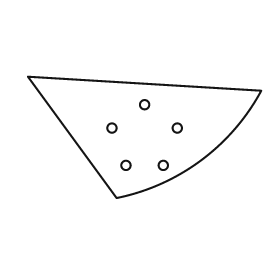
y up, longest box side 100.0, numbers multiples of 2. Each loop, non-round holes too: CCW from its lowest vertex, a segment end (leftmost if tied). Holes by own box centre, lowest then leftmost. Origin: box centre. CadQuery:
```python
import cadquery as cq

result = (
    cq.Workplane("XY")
    .moveTo(-12.0, -26.0)
    .threePointArc((24.0, -10.0), (50.0, 20.0))
    .lineTo(-50.0, 26.0)
    .close()
    .moveTo(-8.0, -12.0)
    .circle(2.0)
    .moveTo(8.0, -12.0)
    .circle(2.0)
    .moveTo(-14.0, 4.0)
    .circle(2.0)
    .moveTo(14.0, 4.0)
    .circle(2.0)
    .moveTo(0.0, 14.0)
    .circle(2.0)
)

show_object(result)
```